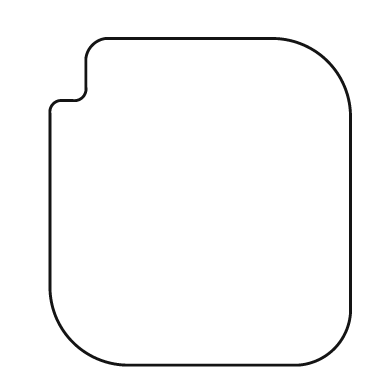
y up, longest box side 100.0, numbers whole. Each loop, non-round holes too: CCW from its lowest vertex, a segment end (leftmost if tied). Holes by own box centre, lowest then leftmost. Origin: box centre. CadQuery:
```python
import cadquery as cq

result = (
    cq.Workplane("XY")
    .moveTo(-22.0, -50.0)
    .lineTo(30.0, -50.0)
    .threePointArc((41.0, -45.0), (46.0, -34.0))
    .lineTo(46.0, 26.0)
    .threePointArc((39.0, 43.0), (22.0, 50.0))
    .lineTo(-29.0, 50.0)
    .threePointArc((-33.0, 48.0), (-35.0, 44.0))
    .lineTo(-35.0, 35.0)
    .threePointArc((-36.0, 32.0), (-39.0, 31.0))
    .lineTo(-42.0, 31.0)
    .threePointArc((-45.0, 30.0), (-46.0, 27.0))
    .lineTo(-46.0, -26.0)
    .threePointArc((-39.0, -43.0), (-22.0, -50.0))
    .close()
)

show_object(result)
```